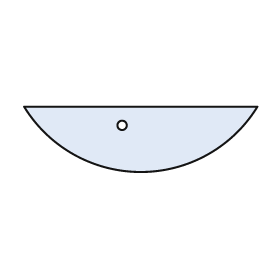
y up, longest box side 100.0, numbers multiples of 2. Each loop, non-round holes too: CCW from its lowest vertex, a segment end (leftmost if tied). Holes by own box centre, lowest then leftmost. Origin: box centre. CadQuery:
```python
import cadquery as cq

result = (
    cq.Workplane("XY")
    .moveTo(-50.0, 14.0)
    .threePointArc((0.0, -14.0), (50.0, 14.0))
    .close()
    .moveTo(-8.0, 6.0)
    .circle(2.0)
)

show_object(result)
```